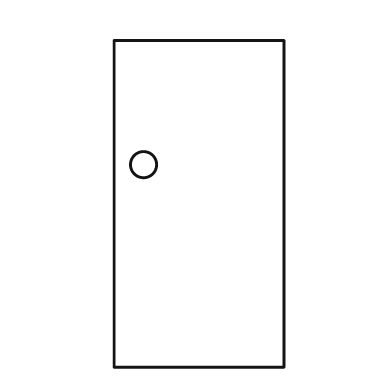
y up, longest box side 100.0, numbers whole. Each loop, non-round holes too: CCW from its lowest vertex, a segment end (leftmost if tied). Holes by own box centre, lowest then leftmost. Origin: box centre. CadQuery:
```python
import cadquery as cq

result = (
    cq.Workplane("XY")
    .moveTo(-26.0, -50.0)
    .lineTo(26.0, -50.0)
    .lineTo(26.0, 50.0)
    .lineTo(-26.0, 50.0)
    .close()
    .moveTo(-17.0, 12.0)
    .circle(4.0)
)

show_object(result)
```